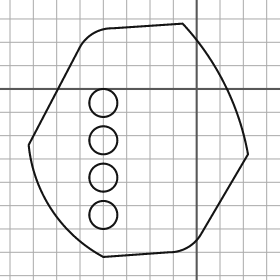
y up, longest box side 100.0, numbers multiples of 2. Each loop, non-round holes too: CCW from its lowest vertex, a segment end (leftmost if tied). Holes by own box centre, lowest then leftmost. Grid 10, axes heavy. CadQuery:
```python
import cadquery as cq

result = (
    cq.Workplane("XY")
    .moveTo(-40.0, -72.0)
    .lineTo(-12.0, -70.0)
    .threePointArc((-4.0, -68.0), (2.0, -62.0))
    .lineTo(22.0, -28.0)
    .threePointArc((12.0, 2.0), (-6.0, 28.0))
    .lineTo(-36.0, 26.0)
    .threePointArc((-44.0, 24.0), (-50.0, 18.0))
    .lineTo(-72.0, -24.0)
    .threePointArc((-62.0, -52.0), (-40.0, -72.0))
    .close()
    .moveTo(-40.0, -54.0)
    .circle(6.0)
    .moveTo(-40.0, -38.0)
    .circle(6.0)
    .moveTo(-40.0, -22.0)
    .circle(6.0)
    .moveTo(-40.0, -6.0)
    .circle(6.0)
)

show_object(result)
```